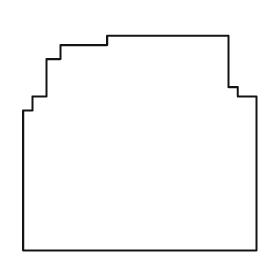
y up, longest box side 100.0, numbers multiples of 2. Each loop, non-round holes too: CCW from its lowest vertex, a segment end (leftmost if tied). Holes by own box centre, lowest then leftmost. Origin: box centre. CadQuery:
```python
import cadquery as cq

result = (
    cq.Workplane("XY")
    .moveTo(-50.0, -46.0)
    .lineTo(50.0, -46.0)
    .lineTo(50.0, 20.0)
    .lineTo(42.0, 20.0)
    .lineTo(42.0, 24.0)
    .lineTo(38.0, 24.0)
    .lineTo(38.0, 46.0)
    .lineTo(-14.0, 46.0)
    .lineTo(-14.0, 42.0)
    .lineTo(-34.0, 42.0)
    .lineTo(-34.0, 36.0)
    .lineTo(-40.0, 36.0)
    .lineTo(-40.0, 20.0)
    .lineTo(-46.0, 20.0)
    .lineTo(-46.0, 14.0)
    .lineTo(-50.0, 14.0)
    .close()
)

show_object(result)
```